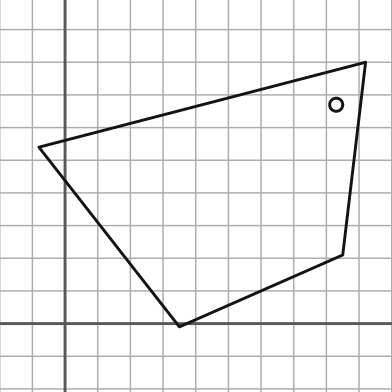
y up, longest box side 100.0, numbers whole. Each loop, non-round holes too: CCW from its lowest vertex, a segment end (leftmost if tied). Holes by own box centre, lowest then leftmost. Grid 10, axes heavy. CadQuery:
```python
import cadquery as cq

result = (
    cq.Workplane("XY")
    .moveTo(35.0, -1.0)
    .lineTo(85.0, 21.0)
    .lineTo(92.0, 80.0)
    .lineTo(-8.0, 54.0)
    .close()
    .moveTo(83.0, 67.0)
    .circle(2.0)
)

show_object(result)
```